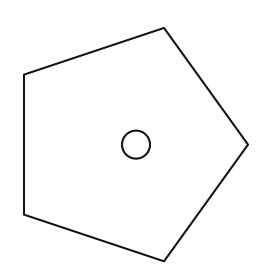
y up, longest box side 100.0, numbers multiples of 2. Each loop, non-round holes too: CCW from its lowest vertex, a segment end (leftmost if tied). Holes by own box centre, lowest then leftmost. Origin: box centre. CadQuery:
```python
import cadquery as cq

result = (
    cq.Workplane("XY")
    .moveTo(12.0, -50.0)
    .lineTo(48.0, 0.0)
    .lineTo(12.0, 50.0)
    .lineTo(-48.0, 30.0)
    .lineTo(-48.0, -30.0)
    .close()
    .moveTo(0.0, 0.0)
    .circle(6.0)
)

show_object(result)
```